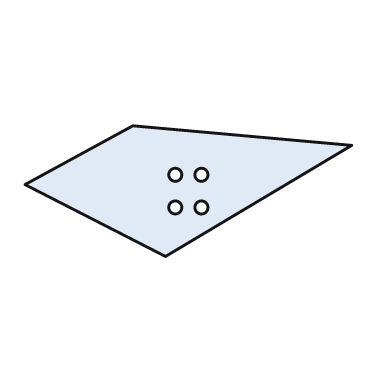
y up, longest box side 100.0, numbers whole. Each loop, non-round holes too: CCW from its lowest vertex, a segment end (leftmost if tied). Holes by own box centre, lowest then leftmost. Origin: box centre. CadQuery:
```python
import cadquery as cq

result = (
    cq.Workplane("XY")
    .moveTo(-7.0, -20.0)
    .lineTo(50.0, 14.0)
    .lineTo(-17.0, 20.0)
    .lineTo(-50.0, 2.0)
    .close()
    .moveTo(-4.0, -5.0)
    .circle(2.0)
    .moveTo(4.0, -5.0)
    .circle(2.0)
    .moveTo(-4.0, 5.0)
    .circle(2.0)
    .moveTo(4.0, 5.0)
    .circle(2.0)
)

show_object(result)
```